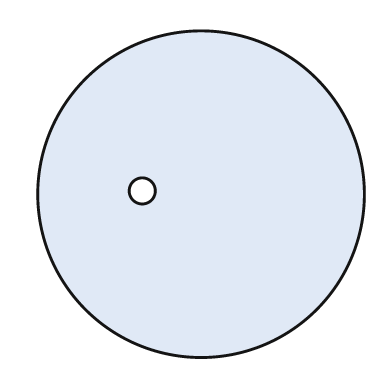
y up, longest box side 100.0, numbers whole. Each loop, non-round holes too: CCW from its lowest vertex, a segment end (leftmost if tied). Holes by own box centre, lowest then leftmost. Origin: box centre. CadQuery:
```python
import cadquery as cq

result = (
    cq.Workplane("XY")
    .moveTo(0.0, 0.0)
    .circle(50.0)
    .moveTo(-18.0, 1.0)
    .circle(4.0)
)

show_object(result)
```